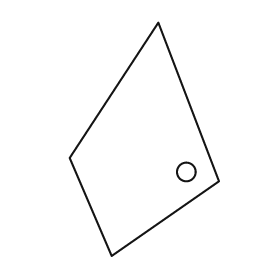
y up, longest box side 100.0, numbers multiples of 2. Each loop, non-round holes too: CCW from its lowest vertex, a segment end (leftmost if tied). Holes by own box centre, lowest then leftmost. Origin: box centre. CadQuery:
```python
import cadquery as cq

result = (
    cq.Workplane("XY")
    .moveTo(-14.0, -50.0)
    .lineTo(32.0, -18.0)
    .lineTo(6.0, 50.0)
    .lineTo(-32.0, -8.0)
    .close()
    .moveTo(18.0, -14.0)
    .circle(4.0)
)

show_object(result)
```